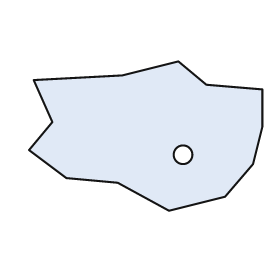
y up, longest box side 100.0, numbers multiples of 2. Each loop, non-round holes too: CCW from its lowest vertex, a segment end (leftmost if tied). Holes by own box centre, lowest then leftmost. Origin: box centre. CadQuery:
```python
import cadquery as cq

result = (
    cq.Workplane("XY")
    .moveTo(10.0, -32.0)
    .lineTo(34.0, -26.0)
    .lineTo(46.0, -12.0)
    .lineTo(50.0, 4.0)
    .lineTo(50.0, 20.0)
    .lineTo(26.0, 22.0)
    .lineTo(14.0, 32.0)
    .lineTo(-10.0, 26.0)
    .lineTo(-48.0, 24.0)
    .lineTo(-40.0, 6.0)
    .lineTo(-50.0, -6.0)
    .lineTo(-34.0, -18.0)
    .lineTo(-12.0, -20.0)
    .close()
    .moveTo(16.0, -8.0)
    .circle(4.0)
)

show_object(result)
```